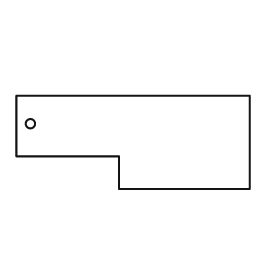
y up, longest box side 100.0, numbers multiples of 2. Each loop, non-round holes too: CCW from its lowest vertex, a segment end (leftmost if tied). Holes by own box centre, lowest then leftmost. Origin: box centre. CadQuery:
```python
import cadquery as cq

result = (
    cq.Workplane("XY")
    .moveTo(-6.0, -20.0)
    .lineTo(50.0, -20.0)
    .lineTo(50.0, 20.0)
    .lineTo(-50.0, 20.0)
    .lineTo(-50.0, -6.0)
    .lineTo(-6.0, -6.0)
    .close()
    .moveTo(-44.0, 8.0)
    .circle(2.0)
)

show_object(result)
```